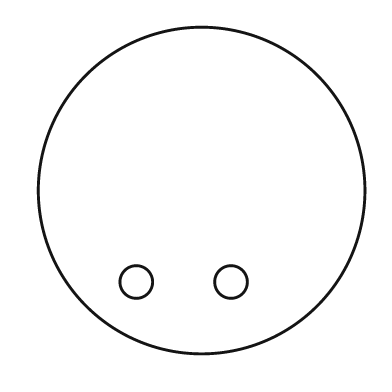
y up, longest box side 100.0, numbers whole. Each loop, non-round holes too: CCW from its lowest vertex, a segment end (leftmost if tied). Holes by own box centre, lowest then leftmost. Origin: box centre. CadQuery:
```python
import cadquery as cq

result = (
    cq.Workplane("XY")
    .moveTo(0.0, 0.0)
    .circle(50.0)
    .moveTo(-20.0, -28.0)
    .circle(5.0)
    .moveTo(9.0, -28.0)
    .circle(5.0)
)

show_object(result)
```